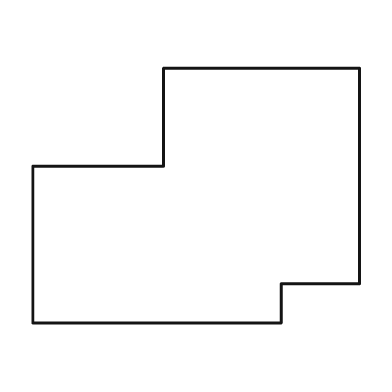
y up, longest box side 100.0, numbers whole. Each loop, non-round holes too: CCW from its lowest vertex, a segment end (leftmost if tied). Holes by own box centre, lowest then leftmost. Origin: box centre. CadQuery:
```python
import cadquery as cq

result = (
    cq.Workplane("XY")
    .moveTo(-50.0, -39.0)
    .lineTo(26.0, -39.0)
    .lineTo(26.0, -27.0)
    .lineTo(50.0, -27.0)
    .lineTo(50.0, 39.0)
    .lineTo(-10.0, 39.0)
    .lineTo(-10.0, 9.0)
    .lineTo(-50.0, 9.0)
    .close()
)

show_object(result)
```